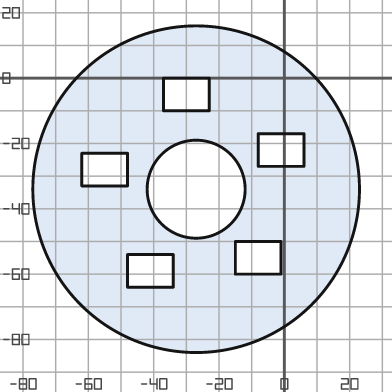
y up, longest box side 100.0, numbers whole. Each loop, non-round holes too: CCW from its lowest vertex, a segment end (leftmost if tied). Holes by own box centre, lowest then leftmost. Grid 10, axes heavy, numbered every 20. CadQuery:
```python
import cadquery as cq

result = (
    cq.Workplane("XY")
    .moveTo(-27.0, -34.0)
    .circle(50.0)
    .moveTo(-48.0, -64.0)
    .lineTo(-34.0, -64.0)
    .lineTo(-34.0, -54.0)
    .lineTo(-48.0, -54.0)
    .close()
    .moveTo(-15.0, -60.0)
    .lineTo(-1.0, -60.0)
    .lineTo(-1.0, -50.0)
    .lineTo(-15.0, -50.0)
    .close()
    .moveTo(-27.0, -34.0)
    .circle(15.0)
    .moveTo(-62.0, -33.0)
    .lineTo(-48.0, -33.0)
    .lineTo(-48.0, -23.0)
    .lineTo(-62.0, -23.0)
    .close()
    .moveTo(-8.0, -27.0)
    .lineTo(6.0, -27.0)
    .lineTo(6.0, -17.0)
    .lineTo(-8.0, -17.0)
    .close()
    .moveTo(-37.0, -10.0)
    .lineTo(-23.0, -10.0)
    .lineTo(-23.0, 0.0)
    .lineTo(-37.0, 0.0)
    .close()
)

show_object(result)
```